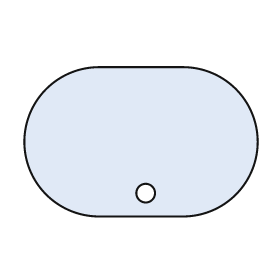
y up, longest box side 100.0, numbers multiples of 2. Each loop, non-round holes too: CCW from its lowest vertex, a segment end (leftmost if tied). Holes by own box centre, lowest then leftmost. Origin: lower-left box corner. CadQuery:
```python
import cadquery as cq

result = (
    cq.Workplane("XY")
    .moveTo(32.0, 0.0)
    .lineTo(68.0, 0.0)
    .threePointArc((100.0, 32.0), (68.0, 64.0))
    .lineTo(32.0, 64.0)
    .threePointArc((0.0, 32.0), (32.0, 0.0))
    .close()
    .moveTo(52.0, 10.0)
    .circle(4.0)
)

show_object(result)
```